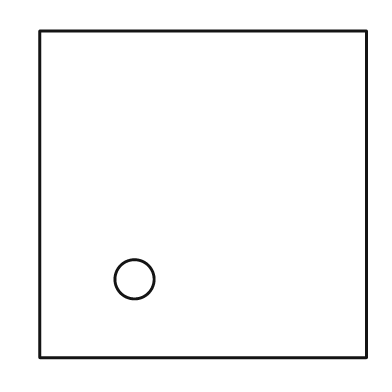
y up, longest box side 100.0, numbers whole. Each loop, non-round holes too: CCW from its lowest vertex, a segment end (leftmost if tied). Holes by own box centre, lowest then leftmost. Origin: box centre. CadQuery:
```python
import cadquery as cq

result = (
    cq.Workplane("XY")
    .moveTo(-50.0, -50.0)
    .lineTo(50.0, -50.0)
    .lineTo(50.0, 50.0)
    .lineTo(-50.0, 50.0)
    .close()
    .moveTo(-21.0, -26.0)
    .circle(6.0)
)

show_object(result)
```